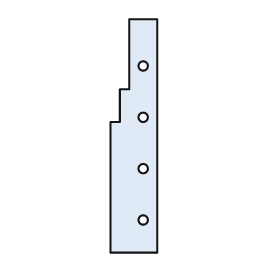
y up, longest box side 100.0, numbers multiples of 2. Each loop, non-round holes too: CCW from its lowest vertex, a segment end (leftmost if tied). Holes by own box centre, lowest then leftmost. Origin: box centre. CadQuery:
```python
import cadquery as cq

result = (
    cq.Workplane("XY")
    .moveTo(-10.0, -50.0)
    .lineTo(10.0, -50.0)
    .lineTo(10.0, 50.0)
    .lineTo(-2.0, 50.0)
    .lineTo(-2.0, 20.0)
    .lineTo(-6.0, 20.0)
    .lineTo(-6.0, 6.0)
    .lineTo(-10.0, 6.0)
    .close()
    .moveTo(4.0, -36.0)
    .circle(2.0)
    .moveTo(4.0, -14.0)
    .circle(2.0)
    .moveTo(4.0, 8.0)
    .circle(2.0)
    .moveTo(4.0, 30.0)
    .circle(2.0)
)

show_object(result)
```